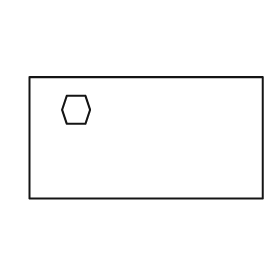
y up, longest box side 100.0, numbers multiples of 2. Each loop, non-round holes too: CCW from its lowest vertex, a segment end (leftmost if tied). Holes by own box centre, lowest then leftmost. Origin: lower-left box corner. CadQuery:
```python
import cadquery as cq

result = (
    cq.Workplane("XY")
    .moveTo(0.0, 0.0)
    .lineTo(100.0, 0.0)
    .lineTo(100.0, 52.0)
    .lineTo(0.0, 52.0)
    .close()
    .moveTo(16.0, 32.0)
    .lineTo(24.0, 32.0)
    .lineTo(26.0, 38.0)
    .lineTo(24.0, 44.0)
    .lineTo(16.0, 44.0)
    .lineTo(14.0, 38.0)
    .close()
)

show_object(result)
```